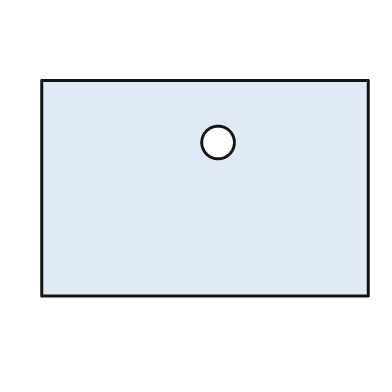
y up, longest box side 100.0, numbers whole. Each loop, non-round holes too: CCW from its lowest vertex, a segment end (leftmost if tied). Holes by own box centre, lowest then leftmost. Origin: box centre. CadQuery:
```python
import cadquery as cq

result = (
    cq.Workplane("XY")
    .moveTo(-50.0, -33.0)
    .lineTo(50.0, -33.0)
    .lineTo(50.0, 33.0)
    .lineTo(-50.0, 33.0)
    .close()
    .moveTo(4.0, 14.0)
    .circle(5.0)
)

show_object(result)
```